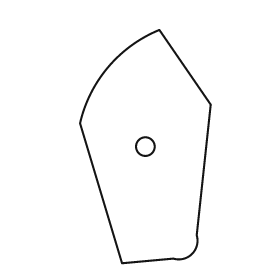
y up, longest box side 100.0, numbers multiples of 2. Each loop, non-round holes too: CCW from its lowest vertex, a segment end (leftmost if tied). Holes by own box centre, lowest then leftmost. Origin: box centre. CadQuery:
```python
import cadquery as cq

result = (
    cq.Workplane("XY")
    .moveTo(-10.0, -50.0)
    .lineTo(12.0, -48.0)
    .threePointArc((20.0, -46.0), (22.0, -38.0))
    .lineTo(28.0, 18.0)
    .lineTo(6.0, 50.0)
    .threePointArc((-16.0, 34.0), (-28.0, 10.0))
    .close()
    .moveTo(0.0, 0.0)
    .circle(4.0)
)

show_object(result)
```